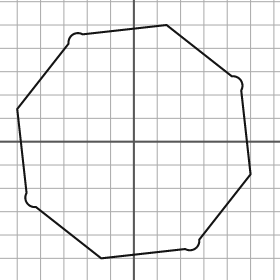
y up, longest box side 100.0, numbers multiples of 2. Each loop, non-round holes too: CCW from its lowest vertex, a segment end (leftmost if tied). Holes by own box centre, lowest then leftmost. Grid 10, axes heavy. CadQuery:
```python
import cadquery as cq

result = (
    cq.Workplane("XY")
    .moveTo(-14.0, -50.0)
    .lineTo(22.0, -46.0)
    .threePointArc((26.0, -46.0), (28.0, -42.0))
    .lineTo(50.0, -14.0)
    .lineTo(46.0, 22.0)
    .threePointArc((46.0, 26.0), (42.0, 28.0))
    .lineTo(14.0, 50.0)
    .lineTo(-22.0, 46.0)
    .threePointArc((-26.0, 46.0), (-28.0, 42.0))
    .lineTo(-50.0, 14.0)
    .lineTo(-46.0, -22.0)
    .threePointArc((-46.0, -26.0), (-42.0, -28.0))
    .close()
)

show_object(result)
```